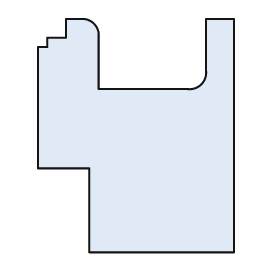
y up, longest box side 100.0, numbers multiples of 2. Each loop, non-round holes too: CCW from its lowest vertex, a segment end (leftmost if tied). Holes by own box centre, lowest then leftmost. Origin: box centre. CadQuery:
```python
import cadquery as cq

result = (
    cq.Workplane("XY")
    .moveTo(-20.0, -50.0)
    .lineTo(42.0, -50.0)
    .lineTo(42.0, 50.0)
    .lineTo(30.0, 50.0)
    .lineTo(30.0, 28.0)
    .threePointArc((28.0, 22.0), (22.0, 20.0))
    .lineTo(-16.0, 20.0)
    .lineTo(-16.0, 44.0)
    .threePointArc((-18.0, 48.0), (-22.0, 50.0))
    .lineTo(-30.0, 50.0)
    .lineTo(-30.0, 42.0)
    .lineTo(-38.0, 42.0)
    .lineTo(-38.0, 38.0)
    .lineTo(-42.0, 38.0)
    .lineTo(-42.0, -14.0)
    .lineTo(-20.0, -14.0)
    .close()
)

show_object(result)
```